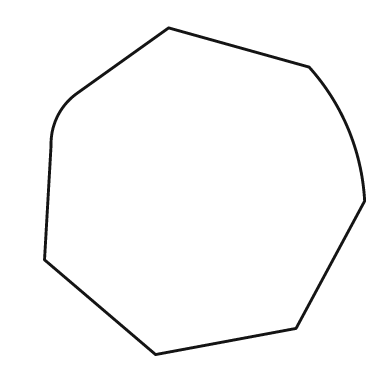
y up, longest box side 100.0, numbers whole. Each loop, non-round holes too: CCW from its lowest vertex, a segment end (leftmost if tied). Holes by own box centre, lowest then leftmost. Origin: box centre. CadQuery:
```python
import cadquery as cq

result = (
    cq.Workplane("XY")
    .moveTo(-15.0, -50.0)
    .lineTo(28.0, -42.0)
    .lineTo(49.0, -3.0)
    .threePointArc((44.0, 19.0), (32.0, 38.0))
    .lineTo(-11.0, 50.0)
    .lineTo(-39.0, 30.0)
    .threePointArc((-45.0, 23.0), (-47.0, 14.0))
    .lineTo(-49.0, -21.0)
    .close()
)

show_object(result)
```